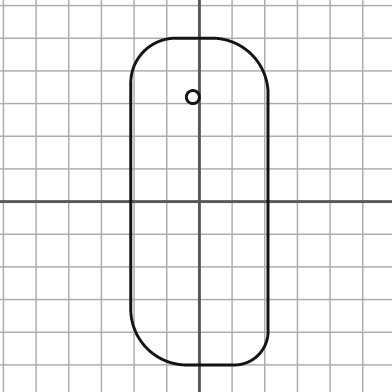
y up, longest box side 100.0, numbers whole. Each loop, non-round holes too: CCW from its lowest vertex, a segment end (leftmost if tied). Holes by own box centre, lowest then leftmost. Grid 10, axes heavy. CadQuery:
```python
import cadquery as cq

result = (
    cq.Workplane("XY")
    .moveTo(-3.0, -50.0)
    .lineTo(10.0, -50.0)
    .threePointArc((18.0, -47.0), (21.0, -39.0))
    .lineTo(21.0, 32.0)
    .threePointArc((16.0, 45.0), (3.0, 50.0))
    .lineTo(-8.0, 50.0)
    .threePointArc((-17.0, 46.0), (-21.0, 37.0))
    .lineTo(-21.0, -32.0)
    .threePointArc((-16.0, -45.0), (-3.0, -50.0))
    .close()
    .moveTo(-2.0, 32.0)
    .circle(2.0)
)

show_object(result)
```